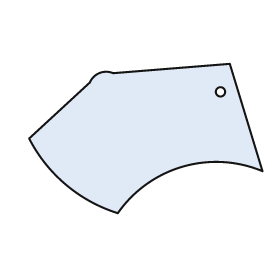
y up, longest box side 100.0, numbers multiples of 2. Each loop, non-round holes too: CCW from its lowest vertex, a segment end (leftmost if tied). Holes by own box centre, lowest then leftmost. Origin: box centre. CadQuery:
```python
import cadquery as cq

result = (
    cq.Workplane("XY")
    .moveTo(-12.0, -32.0)
    .threePointArc((16.0, -12.0), (50.0, -14.0))
    .lineTo(36.0, 32.0)
    .lineTo(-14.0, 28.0)
    .threePointArc((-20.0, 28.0), (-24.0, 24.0))
    .lineTo(-50.0, 0.0)
    .threePointArc((-34.0, -20.0), (-12.0, -32.0))
    .close()
    .moveTo(32.0, 20.0)
    .circle(2.0)
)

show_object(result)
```